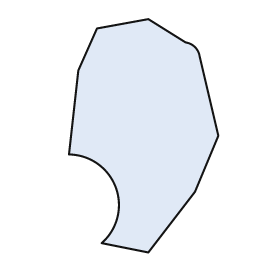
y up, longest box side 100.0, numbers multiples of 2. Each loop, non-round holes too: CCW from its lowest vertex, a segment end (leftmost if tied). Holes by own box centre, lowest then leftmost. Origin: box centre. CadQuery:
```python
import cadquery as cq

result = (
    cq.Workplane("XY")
    .moveTo(2.0, -50.0)
    .lineTo(22.0, -24.0)
    .lineTo(32.0, 0.0)
    .lineTo(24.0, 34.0)
    .threePointArc((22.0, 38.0), (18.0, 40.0))
    .lineTo(2.0, 50.0)
    .lineTo(-20.0, 46.0)
    .lineTo(-28.0, 28.0)
    .lineTo(-32.0, -8.0)
    .threePointArc((-12.0, -22.0), (-18.0, -46.0))
    .close()
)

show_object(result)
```